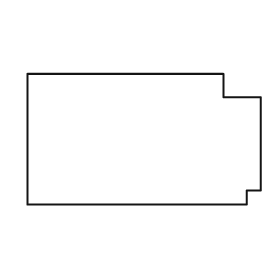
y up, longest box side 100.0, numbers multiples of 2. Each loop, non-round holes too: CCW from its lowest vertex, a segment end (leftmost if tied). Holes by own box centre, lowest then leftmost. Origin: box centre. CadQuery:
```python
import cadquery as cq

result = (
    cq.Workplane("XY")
    .moveTo(-50.0, -28.0)
    .lineTo(44.0, -28.0)
    .lineTo(44.0, -22.0)
    .lineTo(50.0, -22.0)
    .lineTo(50.0, 18.0)
    .lineTo(34.0, 18.0)
    .lineTo(34.0, 28.0)
    .lineTo(-50.0, 28.0)
    .close()
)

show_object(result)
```